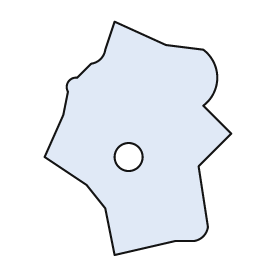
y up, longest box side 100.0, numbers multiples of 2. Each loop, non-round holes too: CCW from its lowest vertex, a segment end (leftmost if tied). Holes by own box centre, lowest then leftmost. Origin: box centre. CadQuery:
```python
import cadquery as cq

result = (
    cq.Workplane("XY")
    .moveTo(-10.0, -50.0)
    .lineTo(16.0, -44.0)
    .lineTo(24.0, -44.0)
    .threePointArc((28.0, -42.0), (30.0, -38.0))
    .lineTo(26.0, -12.0)
    .lineTo(40.0, 2.0)
    .lineTo(28.0, 14.0)
    .threePointArc((34.0, 26.0), (28.0, 38.0))
    .lineTo(12.0, 40.0)
    .lineTo(-10.0, 50.0)
    .lineTo(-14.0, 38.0)
    .threePointArc((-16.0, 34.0), (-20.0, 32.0))
    .lineTo(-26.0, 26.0)
    .threePointArc((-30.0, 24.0), (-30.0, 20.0))
    .lineTo(-32.0, 10.0)
    .lineTo(-40.0, -8.0)
    .lineTo(-22.0, -20.0)
    .lineTo(-14.0, -30.0)
    .close()
    .moveTo(-4.0, -8.0)
    .circle(6.0)
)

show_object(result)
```